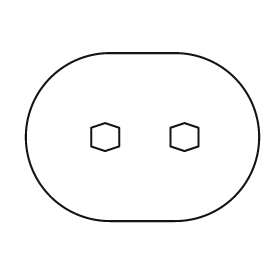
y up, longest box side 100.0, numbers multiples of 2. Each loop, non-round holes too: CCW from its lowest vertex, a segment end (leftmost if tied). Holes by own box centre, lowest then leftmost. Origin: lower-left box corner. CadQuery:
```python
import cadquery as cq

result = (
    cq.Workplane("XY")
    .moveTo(36.0, 0.0)
    .lineTo(64.0, 0.0)
    .threePointArc((100.0, 36.0), (64.0, 72.0))
    .lineTo(36.0, 72.0)
    .threePointArc((0.0, 36.0), (36.0, 0.0))
    .close()
    .moveTo(34.0, 30.0)
    .lineTo(40.0, 32.0)
    .lineTo(40.0, 40.0)
    .lineTo(34.0, 42.0)
    .lineTo(28.0, 40.0)
    .lineTo(28.0, 32.0)
    .close()
    .moveTo(68.0, 30.0)
    .lineTo(74.0, 32.0)
    .lineTo(74.0, 40.0)
    .lineTo(68.0, 42.0)
    .lineTo(62.0, 40.0)
    .lineTo(62.0, 32.0)
    .close()
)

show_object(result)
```